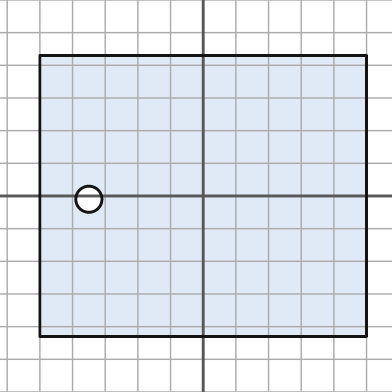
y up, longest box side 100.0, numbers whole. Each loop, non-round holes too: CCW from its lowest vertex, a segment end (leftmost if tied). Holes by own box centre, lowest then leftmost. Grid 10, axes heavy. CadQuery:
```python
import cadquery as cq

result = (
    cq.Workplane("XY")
    .moveTo(-50.0, -43.0)
    .lineTo(50.0, -43.0)
    .lineTo(50.0, 43.0)
    .lineTo(-50.0, 43.0)
    .close()
    .moveTo(-35.0, -1.0)
    .circle(4.0)
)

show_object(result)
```